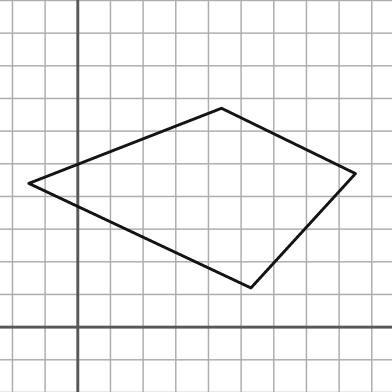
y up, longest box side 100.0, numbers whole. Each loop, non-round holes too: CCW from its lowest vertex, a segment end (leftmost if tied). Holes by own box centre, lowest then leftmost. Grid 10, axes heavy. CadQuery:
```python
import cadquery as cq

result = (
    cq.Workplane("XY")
    .moveTo(53.0, 12.0)
    .lineTo(85.0, 47.0)
    .lineTo(44.0, 67.0)
    .lineTo(-15.0, 44.0)
    .close()
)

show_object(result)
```